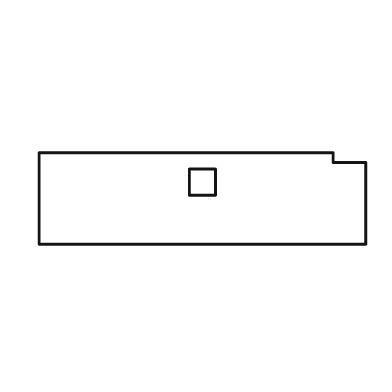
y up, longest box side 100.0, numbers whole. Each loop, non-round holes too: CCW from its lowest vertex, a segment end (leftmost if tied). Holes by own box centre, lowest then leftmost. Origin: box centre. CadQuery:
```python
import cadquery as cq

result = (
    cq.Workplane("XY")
    .moveTo(-50.0, -14.0)
    .lineTo(50.0, -14.0)
    .lineTo(50.0, 11.0)
    .lineTo(40.0, 11.0)
    .lineTo(40.0, 14.0)
    .lineTo(-50.0, 14.0)
    .close()
    .moveTo(-4.0, 1.0)
    .lineTo(4.0, 1.0)
    .lineTo(4.0, 9.0)
    .lineTo(-4.0, 9.0)
    .close()
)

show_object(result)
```